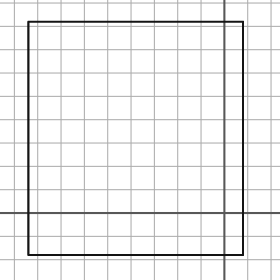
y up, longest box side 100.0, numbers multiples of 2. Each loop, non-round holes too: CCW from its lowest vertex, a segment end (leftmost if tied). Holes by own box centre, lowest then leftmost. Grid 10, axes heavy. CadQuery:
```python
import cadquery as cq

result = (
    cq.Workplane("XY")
    .moveTo(-84.0, -18.0)
    .lineTo(8.0, -18.0)
    .lineTo(8.0, 82.0)
    .lineTo(-84.0, 82.0)
    .close()
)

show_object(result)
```